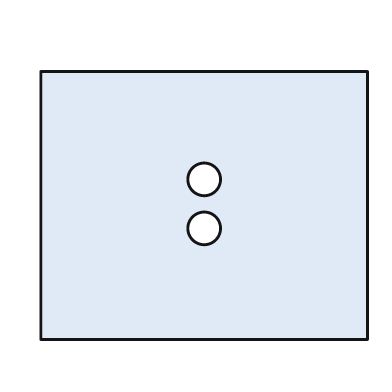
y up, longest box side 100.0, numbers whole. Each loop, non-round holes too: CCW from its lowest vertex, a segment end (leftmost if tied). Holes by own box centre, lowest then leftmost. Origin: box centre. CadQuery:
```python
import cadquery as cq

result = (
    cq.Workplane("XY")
    .moveTo(-50.0, -41.0)
    .lineTo(50.0, -41.0)
    .lineTo(50.0, 41.0)
    .lineTo(-50.0, 41.0)
    .close()
    .moveTo(0.0, -7.0)
    .circle(5.0)
    .moveTo(0.0, 8.0)
    .circle(5.0)
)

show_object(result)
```